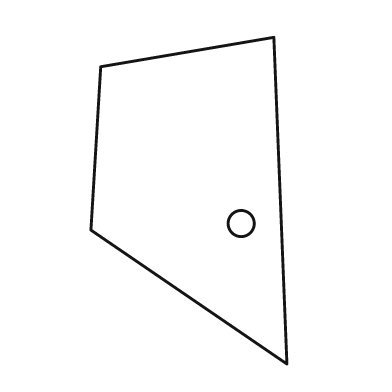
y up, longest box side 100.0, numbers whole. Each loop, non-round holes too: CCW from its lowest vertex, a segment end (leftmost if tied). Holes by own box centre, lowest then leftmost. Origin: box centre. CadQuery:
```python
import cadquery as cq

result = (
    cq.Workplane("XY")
    .moveTo(30.0, -50.0)
    .lineTo(26.0, 50.0)
    .lineTo(-27.0, 41.0)
    .lineTo(-30.0, -9.0)
    .close()
    .moveTo(16.0, -7.0)
    .circle(4.0)
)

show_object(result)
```